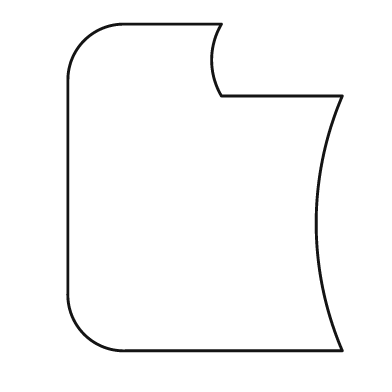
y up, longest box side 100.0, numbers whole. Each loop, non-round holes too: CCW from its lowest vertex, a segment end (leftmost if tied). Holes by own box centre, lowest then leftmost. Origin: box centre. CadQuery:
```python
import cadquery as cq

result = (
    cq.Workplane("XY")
    .moveTo(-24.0, -50.0)
    .lineTo(42.0, -50.0)
    .threePointArc((34.0, -11.0), (42.0, 28.0))
    .lineTo(5.0, 28.0)
    .threePointArc((2.0, 39.0), (5.0, 50.0))
    .lineTo(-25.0, 50.0)
    .threePointArc((-37.0, 45.0), (-42.0, 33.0))
    .lineTo(-42.0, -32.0)
    .threePointArc((-37.0, -45.0), (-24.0, -50.0))
    .close()
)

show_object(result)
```